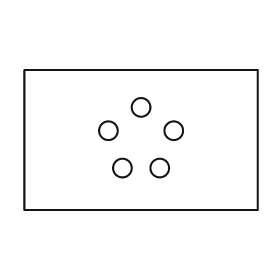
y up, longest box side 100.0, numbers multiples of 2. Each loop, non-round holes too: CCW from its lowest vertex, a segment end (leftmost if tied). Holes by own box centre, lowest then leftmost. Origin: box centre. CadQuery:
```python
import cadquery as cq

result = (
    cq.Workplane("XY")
    .moveTo(-50.0, -30.0)
    .lineTo(50.0, -30.0)
    .lineTo(50.0, 30.0)
    .lineTo(-50.0, 30.0)
    .close()
    .moveTo(-8.0, -12.0)
    .circle(4.0)
    .moveTo(8.0, -12.0)
    .circle(4.0)
    .moveTo(-14.0, 4.0)
    .circle(4.0)
    .moveTo(14.0, 4.0)
    .circle(4.0)
    .moveTo(0.0, 14.0)
    .circle(4.0)
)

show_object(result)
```